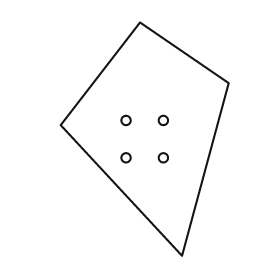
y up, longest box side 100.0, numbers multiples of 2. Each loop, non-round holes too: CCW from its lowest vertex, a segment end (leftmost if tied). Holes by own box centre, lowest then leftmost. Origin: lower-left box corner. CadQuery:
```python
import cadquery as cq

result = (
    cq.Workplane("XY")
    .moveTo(52.0, 0.0)
    .lineTo(72.0, 74.0)
    .lineTo(34.0, 100.0)
    .lineTo(0.0, 56.0)
    .close()
    .moveTo(28.0, 42.0)
    .circle(2.0)
    .moveTo(44.0, 42.0)
    .circle(2.0)
    .moveTo(28.0, 58.0)
    .circle(2.0)
    .moveTo(44.0, 58.0)
    .circle(2.0)
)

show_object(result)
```